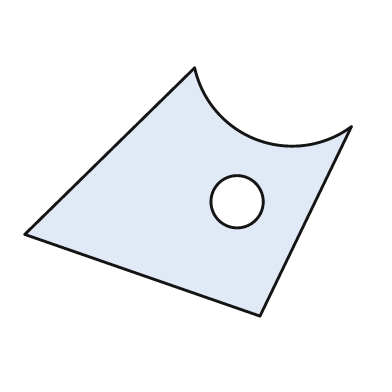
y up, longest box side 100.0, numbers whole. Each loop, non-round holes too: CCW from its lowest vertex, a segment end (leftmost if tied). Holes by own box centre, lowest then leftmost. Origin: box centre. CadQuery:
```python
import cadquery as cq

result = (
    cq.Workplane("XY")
    .moveTo(22.0, -38.0)
    .lineTo(50.0, 20.0)
    .threePointArc((21.0, 16.0), (2.0, 38.0))
    .lineTo(-50.0, -13.0)
    .close()
    .moveTo(15.0, -3.0)
    .circle(8.0)
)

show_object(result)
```